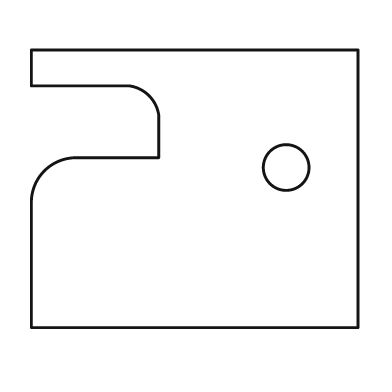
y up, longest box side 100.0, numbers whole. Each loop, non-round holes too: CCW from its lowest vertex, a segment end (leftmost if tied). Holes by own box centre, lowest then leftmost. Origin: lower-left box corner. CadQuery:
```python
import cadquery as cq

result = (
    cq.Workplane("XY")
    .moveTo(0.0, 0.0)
    .lineTo(100.0, 0.0)
    .lineTo(100.0, 85.0)
    .lineTo(0.0, 85.0)
    .lineTo(0.0, 74.0)
    .lineTo(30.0, 74.0)
    .threePointArc((36.0, 71.0), (39.0, 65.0))
    .lineTo(39.0, 52.0)
    .lineTo(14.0, 52.0)
    .threePointArc((4.0, 48.0), (0.0, 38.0))
    .close()
    .moveTo(78.0, 49.0)
    .circle(7.0)
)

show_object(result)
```